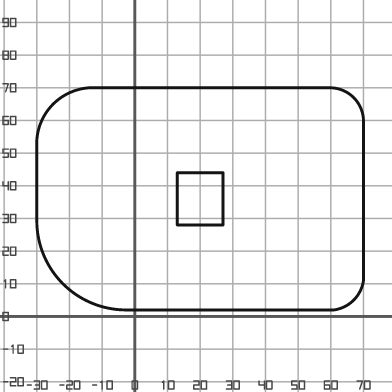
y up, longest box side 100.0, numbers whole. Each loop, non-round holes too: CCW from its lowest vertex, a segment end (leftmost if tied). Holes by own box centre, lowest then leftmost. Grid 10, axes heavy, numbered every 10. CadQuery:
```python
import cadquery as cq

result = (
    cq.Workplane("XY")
    .moveTo(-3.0, 2.0)
    .lineTo(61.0, 2.0)
    .threePointArc((67.0, 5.0), (70.0, 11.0))
    .lineTo(70.0, 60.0)
    .threePointArc((67.0, 67.0), (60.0, 70.0))
    .lineTo(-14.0, 70.0)
    .threePointArc((-25.0, 65.0), (-30.0, 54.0))
    .lineTo(-30.0, 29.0)
    .threePointArc((-22.0, 10.0), (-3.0, 2.0))
    .close()
    .moveTo(13.0, 28.0)
    .lineTo(27.0, 28.0)
    .lineTo(27.0, 44.0)
    .lineTo(13.0, 44.0)
    .close()
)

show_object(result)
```